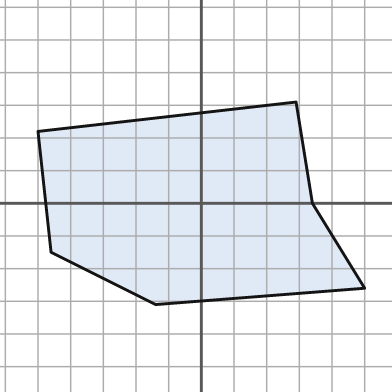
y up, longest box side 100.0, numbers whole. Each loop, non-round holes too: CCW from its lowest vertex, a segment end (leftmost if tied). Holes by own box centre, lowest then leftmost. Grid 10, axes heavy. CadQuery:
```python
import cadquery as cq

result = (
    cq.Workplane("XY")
    .moveTo(-14.0, -31.0)
    .lineTo(50.0, -26.0)
    .lineTo(34.0, 0.0)
    .lineTo(29.0, 31.0)
    .lineTo(-50.0, 22.0)
    .lineTo(-46.0, -15.0)
    .close()
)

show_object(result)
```